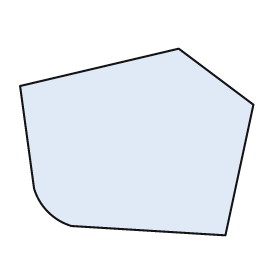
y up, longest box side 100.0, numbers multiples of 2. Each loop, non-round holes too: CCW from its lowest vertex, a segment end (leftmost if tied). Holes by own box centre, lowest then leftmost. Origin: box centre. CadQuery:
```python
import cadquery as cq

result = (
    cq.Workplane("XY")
    .moveTo(38.0, -40.0)
    .lineTo(50.0, 16.0)
    .lineTo(18.0, 40.0)
    .lineTo(-50.0, 24.0)
    .lineTo(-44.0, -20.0)
    .threePointArc((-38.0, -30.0), (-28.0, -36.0))
    .close()
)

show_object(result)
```